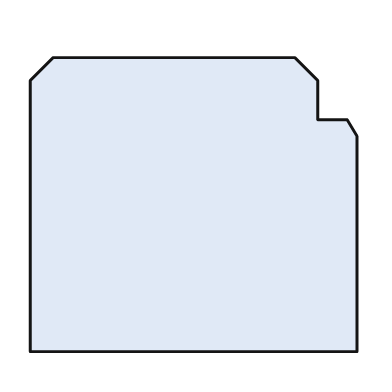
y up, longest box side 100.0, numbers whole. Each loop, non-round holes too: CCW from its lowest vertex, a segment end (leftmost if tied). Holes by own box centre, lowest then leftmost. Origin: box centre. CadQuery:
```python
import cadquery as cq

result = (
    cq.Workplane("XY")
    .moveTo(-50.0, -45.0)
    .lineTo(50.0, -45.0)
    .lineTo(50.0, 21.0)
    .lineTo(47.0, 26.0)
    .lineTo(38.0, 26.0)
    .lineTo(38.0, 38.0)
    .lineTo(31.0, 45.0)
    .lineTo(-43.0, 45.0)
    .lineTo(-50.0, 38.0)
    .close()
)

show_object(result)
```